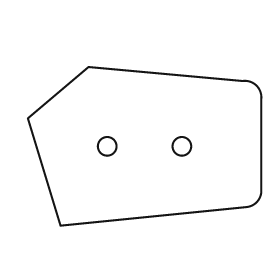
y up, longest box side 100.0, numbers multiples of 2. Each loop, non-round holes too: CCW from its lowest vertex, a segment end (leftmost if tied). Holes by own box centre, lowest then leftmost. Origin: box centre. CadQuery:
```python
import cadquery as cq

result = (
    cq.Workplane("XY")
    .moveTo(-36.0, -34.0)
    .lineTo(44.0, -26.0)
    .threePointArc((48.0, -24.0), (50.0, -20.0))
    .lineTo(50.0, 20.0)
    .threePointArc((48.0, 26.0), (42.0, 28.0))
    .lineTo(-24.0, 34.0)
    .lineTo(-50.0, 12.0)
    .close()
    .moveTo(-16.0, 0.0)
    .circle(4.0)
    .moveTo(16.0, 0.0)
    .circle(4.0)
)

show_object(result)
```